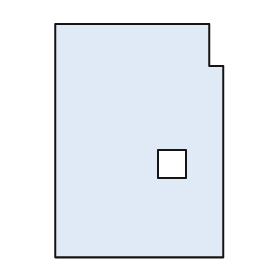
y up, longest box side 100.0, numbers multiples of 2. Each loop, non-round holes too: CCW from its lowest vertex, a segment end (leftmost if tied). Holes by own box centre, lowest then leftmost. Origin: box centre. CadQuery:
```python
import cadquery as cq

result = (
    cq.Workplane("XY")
    .moveTo(-36.0, -50.0)
    .lineTo(36.0, -50.0)
    .lineTo(36.0, 32.0)
    .lineTo(30.0, 32.0)
    .lineTo(30.0, 50.0)
    .lineTo(-36.0, 50.0)
    .close()
    .moveTo(8.0, -16.0)
    .lineTo(20.0, -16.0)
    .lineTo(20.0, -4.0)
    .lineTo(8.0, -4.0)
    .close()
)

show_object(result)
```